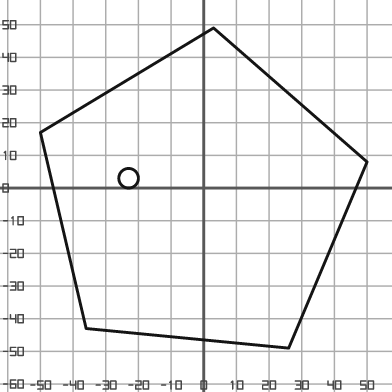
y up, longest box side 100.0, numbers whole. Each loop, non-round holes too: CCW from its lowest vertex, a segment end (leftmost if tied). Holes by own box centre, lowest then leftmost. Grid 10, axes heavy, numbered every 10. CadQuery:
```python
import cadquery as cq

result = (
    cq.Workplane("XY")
    .moveTo(26.0, -49.0)
    .lineTo(50.0, 8.0)
    .lineTo(3.0, 49.0)
    .lineTo(-50.0, 17.0)
    .lineTo(-36.0, -43.0)
    .close()
    .moveTo(-23.0, 3.0)
    .circle(3.0)
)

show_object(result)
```